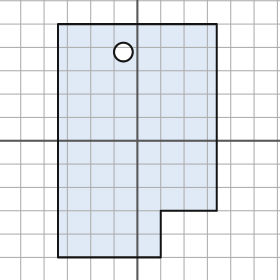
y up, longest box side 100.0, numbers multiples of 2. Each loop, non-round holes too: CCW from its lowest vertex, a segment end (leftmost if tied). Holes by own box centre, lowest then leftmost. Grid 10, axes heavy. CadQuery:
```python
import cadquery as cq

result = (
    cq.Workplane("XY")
    .moveTo(-34.0, -50.0)
    .lineTo(10.0, -50.0)
    .lineTo(10.0, -30.0)
    .lineTo(34.0, -30.0)
    .lineTo(34.0, 50.0)
    .lineTo(-34.0, 50.0)
    .close()
    .moveTo(-6.0, 38.0)
    .circle(4.0)
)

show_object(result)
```